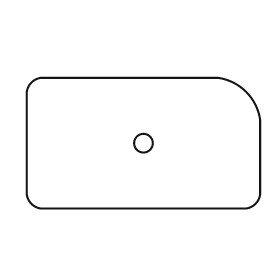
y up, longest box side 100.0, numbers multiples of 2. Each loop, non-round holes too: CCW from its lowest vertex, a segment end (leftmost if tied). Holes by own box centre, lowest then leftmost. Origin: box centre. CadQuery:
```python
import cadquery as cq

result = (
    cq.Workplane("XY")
    .moveTo(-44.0, -28.0)
    .lineTo(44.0, -28.0)
    .threePointArc((48.0, -26.0), (50.0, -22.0))
    .lineTo(50.0, 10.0)
    .threePointArc((44.0, 22.0), (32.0, 28.0))
    .lineTo(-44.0, 28.0)
    .threePointArc((-48.0, 26.0), (-50.0, 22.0))
    .lineTo(-50.0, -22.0)
    .threePointArc((-48.0, -26.0), (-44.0, -28.0))
    .close()
    .moveTo(0.0, 0.0)
    .circle(4.0)
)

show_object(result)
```